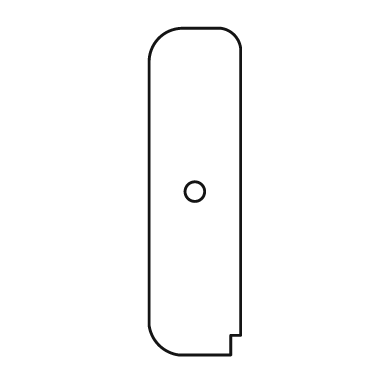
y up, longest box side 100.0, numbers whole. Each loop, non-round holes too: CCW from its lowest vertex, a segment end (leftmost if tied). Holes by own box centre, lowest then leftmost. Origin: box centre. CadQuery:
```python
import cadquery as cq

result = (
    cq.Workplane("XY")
    .moveTo(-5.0, -50.0)
    .lineTo(11.0, -50.0)
    .lineTo(11.0, -44.0)
    .lineTo(14.0, -44.0)
    .lineTo(14.0, 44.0)
    .threePointArc((12.0, 48.0), (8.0, 50.0))
    .lineTo(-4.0, 50.0)
    .threePointArc((-11.0, 47.0), (-14.0, 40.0))
    .lineTo(-14.0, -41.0)
    .threePointArc((-11.0, -47.0), (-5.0, -50.0))
    .close()
    .moveTo(0.0, 0.0)
    .circle(3.0)
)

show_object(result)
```